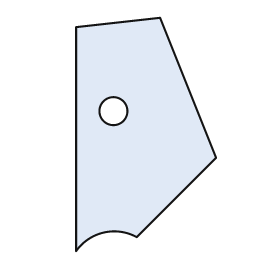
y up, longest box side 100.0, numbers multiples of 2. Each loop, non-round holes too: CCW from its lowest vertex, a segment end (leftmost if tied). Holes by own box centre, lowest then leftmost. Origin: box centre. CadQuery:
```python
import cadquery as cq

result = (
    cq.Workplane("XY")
    .moveTo(-30.0, -50.0)
    .threePointArc((-18.0, -42.0), (-4.0, -44.0))
    .lineTo(30.0, -10.0)
    .lineTo(6.0, 50.0)
    .lineTo(-30.0, 46.0)
    .close()
    .moveTo(-14.0, 10.0)
    .circle(6.0)
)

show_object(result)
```